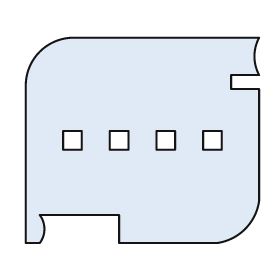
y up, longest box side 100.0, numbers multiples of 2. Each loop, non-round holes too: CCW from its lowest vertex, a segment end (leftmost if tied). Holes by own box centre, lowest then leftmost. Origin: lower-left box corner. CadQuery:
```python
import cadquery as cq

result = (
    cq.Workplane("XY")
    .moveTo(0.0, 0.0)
    .lineTo(6.0, 0.0)
    .threePointArc((8.0, 6.0), (6.0, 12.0))
    .lineTo(40.0, 12.0)
    .lineTo(40.0, 0.0)
    .lineTo(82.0, 0.0)
    .threePointArc((94.0, 6.0), (100.0, 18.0))
    .lineTo(100.0, 66.0)
    .lineTo(88.0, 66.0)
    .lineTo(88.0, 72.0)
    .lineTo(100.0, 72.0)
    .threePointArc((98.0, 80.0), (100.0, 88.0))
    .lineTo(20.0, 88.0)
    .threePointArc((6.0, 82.0), (0.0, 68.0))
    .close()
    .moveTo(16.0, 40.0)
    .lineTo(24.0, 40.0)
    .lineTo(24.0, 48.0)
    .lineTo(16.0, 48.0)
    .close()
    .moveTo(36.0, 40.0)
    .lineTo(44.0, 40.0)
    .lineTo(44.0, 48.0)
    .lineTo(36.0, 48.0)
    .close()
    .moveTo(56.0, 40.0)
    .lineTo(64.0, 40.0)
    .lineTo(64.0, 48.0)
    .lineTo(56.0, 48.0)
    .close()
    .moveTo(76.0, 40.0)
    .lineTo(84.0, 40.0)
    .lineTo(84.0, 48.0)
    .lineTo(76.0, 48.0)
    .close()
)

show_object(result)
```